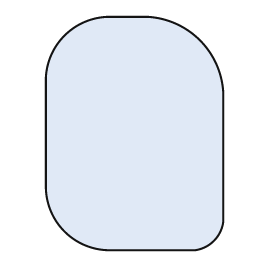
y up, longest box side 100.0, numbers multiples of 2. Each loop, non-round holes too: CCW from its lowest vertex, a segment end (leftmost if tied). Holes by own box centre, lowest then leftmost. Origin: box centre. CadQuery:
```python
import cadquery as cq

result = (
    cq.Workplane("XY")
    .moveTo(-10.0, -50.0)
    .lineTo(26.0, -50.0)
    .threePointArc((34.0, -46.0), (38.0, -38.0))
    .lineTo(38.0, 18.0)
    .threePointArc((28.0, 40.0), (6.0, 50.0))
    .lineTo(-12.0, 50.0)
    .threePointArc((-30.0, 42.0), (-38.0, 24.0))
    .lineTo(-38.0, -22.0)
    .threePointArc((-30.0, -42.0), (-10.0, -50.0))
    .close()
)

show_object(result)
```